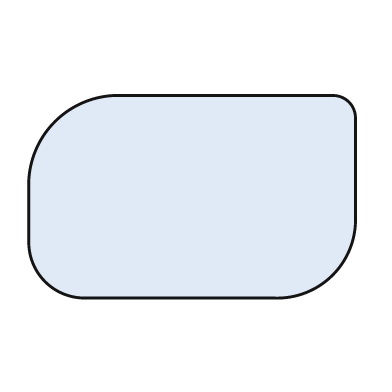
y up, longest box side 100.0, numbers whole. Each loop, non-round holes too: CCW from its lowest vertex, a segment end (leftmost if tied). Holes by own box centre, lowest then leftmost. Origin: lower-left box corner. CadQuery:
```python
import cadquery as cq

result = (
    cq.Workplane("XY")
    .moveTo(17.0, 0.0)
    .lineTo(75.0, 0.0)
    .threePointArc((93.0, 7.0), (100.0, 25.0))
    .lineTo(100.0, 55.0)
    .threePointArc((98.0, 60.0), (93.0, 62.0))
    .lineTo(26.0, 62.0)
    .threePointArc((8.0, 54.0), (0.0, 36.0))
    .lineTo(0.0, 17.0)
    .threePointArc((5.0, 5.0), (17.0, 0.0))
    .close()
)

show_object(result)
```